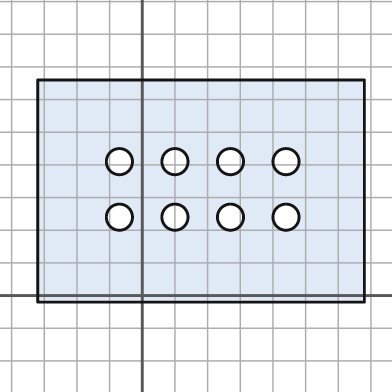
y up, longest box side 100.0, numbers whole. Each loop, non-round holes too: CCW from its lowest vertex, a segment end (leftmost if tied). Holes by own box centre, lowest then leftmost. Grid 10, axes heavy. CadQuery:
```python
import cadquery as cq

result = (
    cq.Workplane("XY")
    .moveTo(-32.0, -2.0)
    .lineTo(68.0, -2.0)
    .lineTo(68.0, 66.0)
    .lineTo(-32.0, 66.0)
    .close()
    .moveTo(-7.0, 24.0)
    .circle(4.0)
    .moveTo(10.0, 24.0)
    .circle(4.0)
    .moveTo(27.0, 24.0)
    .circle(4.0)
    .moveTo(44.0, 24.0)
    .circle(4.0)
    .moveTo(-7.0, 41.0)
    .circle(4.0)
    .moveTo(10.0, 41.0)
    .circle(4.0)
    .moveTo(27.0, 41.0)
    .circle(4.0)
    .moveTo(44.0, 41.0)
    .circle(4.0)
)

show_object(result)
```